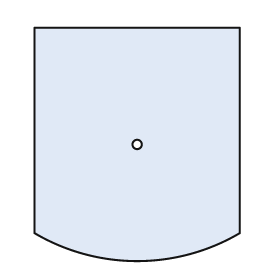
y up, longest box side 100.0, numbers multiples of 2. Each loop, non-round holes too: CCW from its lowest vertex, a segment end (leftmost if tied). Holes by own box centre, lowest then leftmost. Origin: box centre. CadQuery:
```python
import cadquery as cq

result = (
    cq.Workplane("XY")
    .moveTo(-44.0, -38.0)
    .threePointArc((0.0, -50.0), (44.0, -38.0))
    .lineTo(44.0, 50.0)
    .lineTo(-44.0, 50.0)
    .close()
    .moveTo(0.0, 0.0)
    .circle(2.0)
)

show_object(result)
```